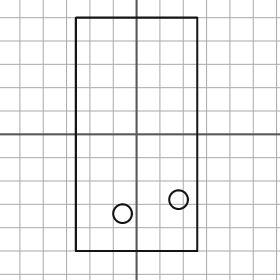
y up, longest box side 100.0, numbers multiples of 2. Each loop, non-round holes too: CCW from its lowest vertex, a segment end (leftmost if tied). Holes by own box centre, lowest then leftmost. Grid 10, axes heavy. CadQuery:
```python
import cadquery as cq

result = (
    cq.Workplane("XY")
    .moveTo(-26.0, -50.0)
    .lineTo(26.0, -50.0)
    .lineTo(26.0, 50.0)
    .lineTo(-26.0, 50.0)
    .close()
    .moveTo(-6.0, -34.0)
    .circle(4.0)
    .moveTo(18.0, -28.0)
    .circle(4.0)
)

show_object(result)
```